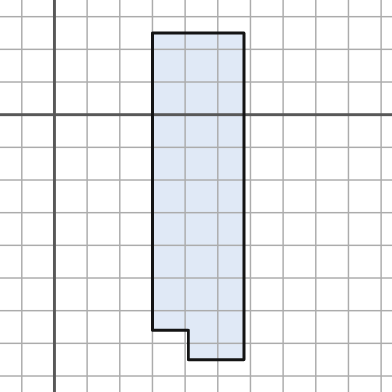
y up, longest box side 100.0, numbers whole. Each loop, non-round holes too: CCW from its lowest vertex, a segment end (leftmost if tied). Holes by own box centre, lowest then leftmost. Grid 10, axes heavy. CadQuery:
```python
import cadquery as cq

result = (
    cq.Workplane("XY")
    .moveTo(41.0, -75.0)
    .lineTo(58.0, -75.0)
    .lineTo(58.0, 25.0)
    .lineTo(30.0, 25.0)
    .lineTo(30.0, -66.0)
    .lineTo(41.0, -66.0)
    .close()
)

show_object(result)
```